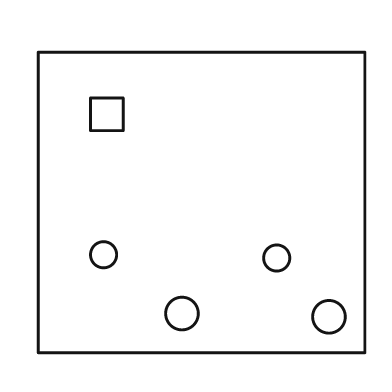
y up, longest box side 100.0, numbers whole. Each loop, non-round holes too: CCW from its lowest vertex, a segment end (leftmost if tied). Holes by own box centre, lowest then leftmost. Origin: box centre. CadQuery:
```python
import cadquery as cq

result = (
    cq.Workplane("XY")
    .moveTo(-50.0, -46.0)
    .lineTo(50.0, -46.0)
    .lineTo(50.0, 46.0)
    .lineTo(-50.0, 46.0)
    .close()
    .moveTo(39.0, -35.0)
    .circle(5.0)
    .moveTo(-6.0, -34.0)
    .circle(5.0)
    .moveTo(23.0, -17.0)
    .circle(4.0)
    .moveTo(-30.0, -16.0)
    .circle(4.0)
    .moveTo(-34.0, 22.0)
    .lineTo(-24.0, 22.0)
    .lineTo(-24.0, 32.0)
    .lineTo(-34.0, 32.0)
    .close()
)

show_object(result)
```